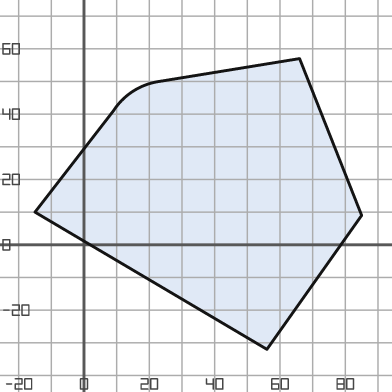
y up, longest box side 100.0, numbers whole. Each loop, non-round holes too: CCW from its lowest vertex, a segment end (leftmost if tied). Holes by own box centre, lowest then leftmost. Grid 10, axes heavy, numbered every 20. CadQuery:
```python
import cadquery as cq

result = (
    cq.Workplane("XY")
    .moveTo(56.0, -32.0)
    .lineTo(85.0, 9.0)
    .lineTo(66.0, 57.0)
    .lineTo(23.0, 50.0)
    .threePointArc((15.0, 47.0), (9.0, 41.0))
    .lineTo(-15.0, 10.0)
    .close()
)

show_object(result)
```